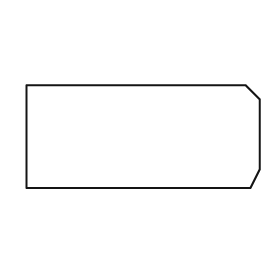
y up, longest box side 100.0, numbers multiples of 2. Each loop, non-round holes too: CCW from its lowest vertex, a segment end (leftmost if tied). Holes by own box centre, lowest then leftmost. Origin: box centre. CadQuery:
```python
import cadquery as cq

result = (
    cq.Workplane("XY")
    .moveTo(-50.0, -22.0)
    .lineTo(46.0, -22.0)
    .lineTo(50.0, -14.0)
    .lineTo(50.0, 16.0)
    .lineTo(44.0, 22.0)
    .lineTo(-50.0, 22.0)
    .close()
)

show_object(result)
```